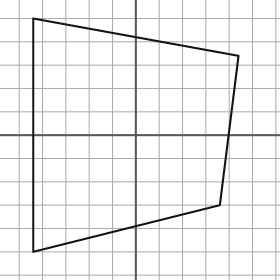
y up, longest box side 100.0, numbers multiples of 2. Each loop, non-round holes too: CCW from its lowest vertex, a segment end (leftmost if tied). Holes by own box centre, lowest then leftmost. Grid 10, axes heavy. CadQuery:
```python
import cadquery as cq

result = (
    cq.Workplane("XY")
    .moveTo(-44.0, -50.0)
    .lineTo(36.0, -30.0)
    .lineTo(44.0, 34.0)
    .lineTo(-44.0, 50.0)
    .close()
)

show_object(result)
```